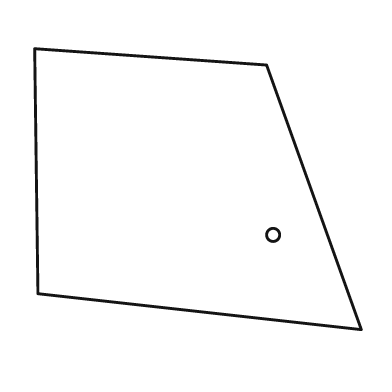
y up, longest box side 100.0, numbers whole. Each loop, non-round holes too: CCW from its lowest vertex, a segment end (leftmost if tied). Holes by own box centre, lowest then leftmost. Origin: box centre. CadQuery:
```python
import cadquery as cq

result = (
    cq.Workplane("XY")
    .moveTo(50.0, -43.0)
    .lineTo(21.0, 38.0)
    .lineTo(-50.0, 43.0)
    .lineTo(-49.0, -32.0)
    .close()
    .moveTo(23.0, -14.0)
    .circle(2.0)
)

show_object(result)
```